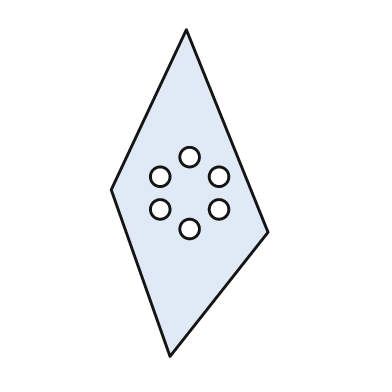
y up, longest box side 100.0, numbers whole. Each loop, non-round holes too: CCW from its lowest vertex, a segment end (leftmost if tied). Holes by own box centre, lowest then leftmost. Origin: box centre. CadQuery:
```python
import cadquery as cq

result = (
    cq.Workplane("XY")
    .moveTo(-6.0, -50.0)
    .lineTo(24.0, -12.0)
    .lineTo(-1.0, 50.0)
    .lineTo(-24.0, 1.0)
    .close()
    .moveTo(0.0, -11.0)
    .circle(3.0)
    .moveTo(-9.0, -5.0)
    .circle(3.0)
    .moveTo(9.0, -5.0)
    .circle(3.0)
    .moveTo(-9.0, 5.0)
    .circle(3.0)
    .moveTo(9.0, 5.0)
    .circle(3.0)
    .moveTo(0.0, 11.0)
    .circle(3.0)
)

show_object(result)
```